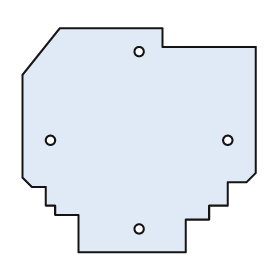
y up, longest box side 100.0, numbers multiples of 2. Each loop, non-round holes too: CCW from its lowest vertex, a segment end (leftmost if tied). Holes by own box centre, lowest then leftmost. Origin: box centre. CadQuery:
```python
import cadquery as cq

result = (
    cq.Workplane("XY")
    .moveTo(-26.0, -48.0)
    .lineTo(20.0, -48.0)
    .lineTo(20.0, -34.0)
    .lineTo(30.0, -34.0)
    .lineTo(30.0, -28.0)
    .lineTo(38.0, -28.0)
    .lineTo(38.0, -18.0)
    .lineTo(46.0, -18.0)
    .lineTo(50.0, -14.0)
    .lineTo(50.0, 40.0)
    .lineTo(10.0, 40.0)
    .lineTo(10.0, 48.0)
    .lineTo(-34.0, 48.0)
    .lineTo(-50.0, 28.0)
    .lineTo(-50.0, -16.0)
    .lineTo(-46.0, -20.0)
    .lineTo(-40.0, -20.0)
    .lineTo(-40.0, -28.0)
    .lineTo(-36.0, -28.0)
    .lineTo(-36.0, -32.0)
    .lineTo(-26.0, -32.0)
    .close()
    .moveTo(0.0, -38.0)
    .circle(2.0)
    .moveTo(-38.0, 0.0)
    .circle(2.0)
    .moveTo(38.0, 0.0)
    .circle(2.0)
    .moveTo(0.0, 38.0)
    .circle(2.0)
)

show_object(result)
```